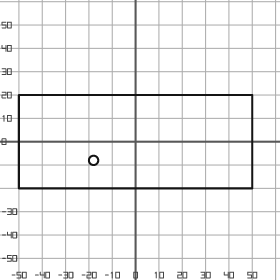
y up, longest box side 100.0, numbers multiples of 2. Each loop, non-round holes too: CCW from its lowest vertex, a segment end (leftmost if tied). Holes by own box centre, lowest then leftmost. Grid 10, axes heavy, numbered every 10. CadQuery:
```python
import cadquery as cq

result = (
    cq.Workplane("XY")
    .moveTo(-50.0, -20.0)
    .lineTo(50.0, -20.0)
    .lineTo(50.0, 20.0)
    .lineTo(-50.0, 20.0)
    .close()
    .moveTo(-18.0, -8.0)
    .circle(2.0)
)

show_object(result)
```